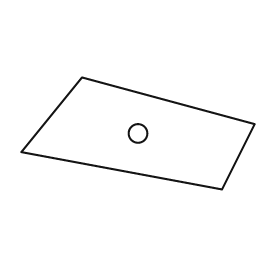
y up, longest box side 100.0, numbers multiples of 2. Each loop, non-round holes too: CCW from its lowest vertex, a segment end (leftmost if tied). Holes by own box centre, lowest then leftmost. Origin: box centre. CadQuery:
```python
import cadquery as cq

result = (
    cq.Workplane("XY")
    .moveTo(36.0, -24.0)
    .lineTo(50.0, 4.0)
    .lineTo(-24.0, 24.0)
    .lineTo(-50.0, -8.0)
    .close()
    .moveTo(0.0, 0.0)
    .circle(4.0)
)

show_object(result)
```